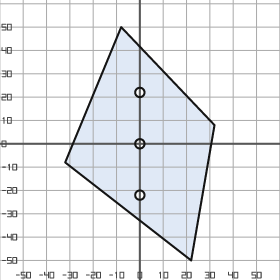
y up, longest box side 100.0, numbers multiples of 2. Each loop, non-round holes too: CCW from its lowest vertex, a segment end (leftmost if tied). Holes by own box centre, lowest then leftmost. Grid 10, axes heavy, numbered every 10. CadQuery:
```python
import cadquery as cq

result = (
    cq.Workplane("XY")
    .moveTo(22.0, -50.0)
    .lineTo(32.0, 8.0)
    .lineTo(-8.0, 50.0)
    .lineTo(-32.0, -8.0)
    .close()
    .moveTo(0.0, -22.0)
    .circle(2.0)
    .moveTo(0.0, 0.0)
    .circle(2.0)
    .moveTo(0.0, 22.0)
    .circle(2.0)
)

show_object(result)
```